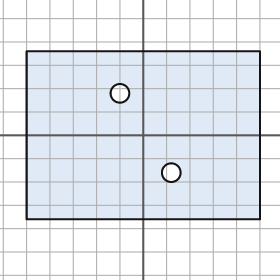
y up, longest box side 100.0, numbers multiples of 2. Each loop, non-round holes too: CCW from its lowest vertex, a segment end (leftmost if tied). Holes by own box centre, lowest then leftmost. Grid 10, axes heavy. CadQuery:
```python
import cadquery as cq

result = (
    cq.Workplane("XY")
    .moveTo(-50.0, -36.0)
    .lineTo(50.0, -36.0)
    .lineTo(50.0, 36.0)
    .lineTo(-50.0, 36.0)
    .close()
    .moveTo(12.0, -16.0)
    .circle(4.0)
    .moveTo(-10.0, 18.0)
    .circle(4.0)
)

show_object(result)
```